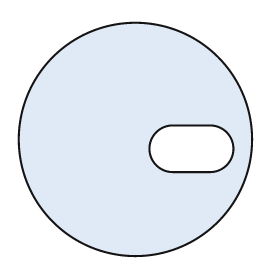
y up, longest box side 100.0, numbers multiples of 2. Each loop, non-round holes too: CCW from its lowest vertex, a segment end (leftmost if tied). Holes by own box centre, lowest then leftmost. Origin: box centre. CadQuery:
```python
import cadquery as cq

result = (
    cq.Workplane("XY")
    .moveTo(0.0, 0.0)
    .circle(50.0)
    .moveTo(16.0, -14.0)
    .lineTo(32.0, -14.0)
    .threePointArc((42.0, -4.0), (32.0, 6.0))
    .lineTo(16.0, 6.0)
    .threePointArc((6.0, -4.0), (16.0, -14.0))
    .close()
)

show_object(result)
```